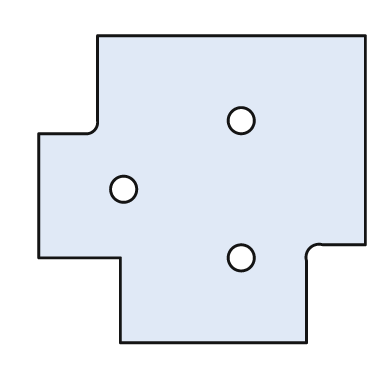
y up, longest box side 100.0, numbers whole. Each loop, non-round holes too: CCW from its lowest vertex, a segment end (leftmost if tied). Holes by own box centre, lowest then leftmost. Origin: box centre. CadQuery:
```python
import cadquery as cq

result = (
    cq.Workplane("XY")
    .moveTo(-25.0, -47.0)
    .lineTo(32.0, -47.0)
    .lineTo(32.0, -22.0)
    .threePointArc((33.0, -18.0), (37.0, -17.0))
    .lineTo(50.0, -17.0)
    .lineTo(50.0, 47.0)
    .lineTo(-32.0, 47.0)
    .lineTo(-32.0, 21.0)
    .threePointArc((-33.0, 18.0), (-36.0, 17.0))
    .lineTo(-50.0, 17.0)
    .lineTo(-50.0, -21.0)
    .lineTo(-25.0, -21.0)
    .close()
    .moveTo(12.0, -21.0)
    .circle(4.0)
    .moveTo(-24.0, 0.0)
    .circle(4.0)
    .moveTo(12.0, 21.0)
    .circle(4.0)
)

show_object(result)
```